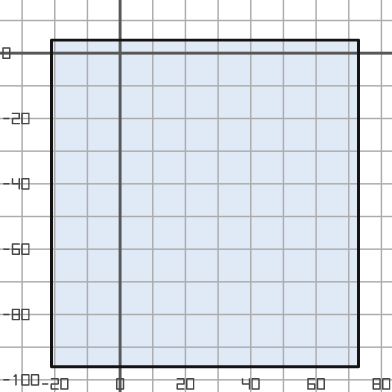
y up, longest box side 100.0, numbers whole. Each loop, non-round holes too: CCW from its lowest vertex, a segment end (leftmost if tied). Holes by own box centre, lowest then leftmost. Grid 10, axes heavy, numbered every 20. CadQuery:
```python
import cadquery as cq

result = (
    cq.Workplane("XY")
    .moveTo(-21.0, -96.0)
    .lineTo(73.0, -96.0)
    .lineTo(73.0, 4.0)
    .lineTo(-21.0, 4.0)
    .close()
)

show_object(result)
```